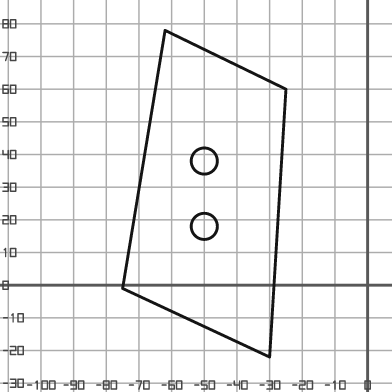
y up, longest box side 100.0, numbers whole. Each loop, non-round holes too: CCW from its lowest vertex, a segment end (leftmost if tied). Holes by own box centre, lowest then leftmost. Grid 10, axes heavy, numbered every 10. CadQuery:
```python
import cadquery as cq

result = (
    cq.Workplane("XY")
    .moveTo(-30.0, -22.0)
    .lineTo(-25.0, 60.0)
    .lineTo(-62.0, 78.0)
    .lineTo(-75.0, -1.0)
    .close()
    .moveTo(-50.0, 18.0)
    .circle(4.0)
    .moveTo(-50.0, 38.0)
    .circle(4.0)
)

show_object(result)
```